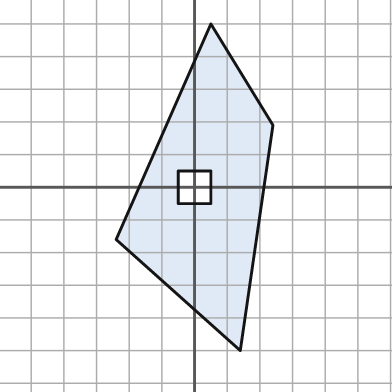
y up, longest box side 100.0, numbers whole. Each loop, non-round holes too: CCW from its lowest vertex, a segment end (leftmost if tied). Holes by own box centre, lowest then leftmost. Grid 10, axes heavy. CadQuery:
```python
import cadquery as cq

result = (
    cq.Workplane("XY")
    .moveTo(14.0, -50.0)
    .lineTo(24.0, 19.0)
    .lineTo(5.0, 50.0)
    .lineTo(-24.0, -16.0)
    .close()
    .moveTo(-5.0, -5.0)
    .lineTo(5.0, -5.0)
    .lineTo(5.0, 5.0)
    .lineTo(-5.0, 5.0)
    .close()
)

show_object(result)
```